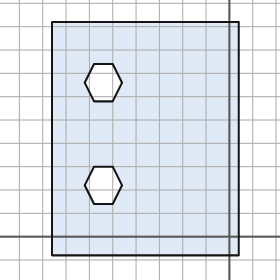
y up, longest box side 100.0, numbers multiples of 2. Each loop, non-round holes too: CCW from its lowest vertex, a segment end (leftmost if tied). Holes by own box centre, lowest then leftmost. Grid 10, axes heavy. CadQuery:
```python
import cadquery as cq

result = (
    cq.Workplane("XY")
    .moveTo(-76.0, -8.0)
    .lineTo(4.0, -8.0)
    .lineTo(4.0, 92.0)
    .lineTo(-76.0, 92.0)
    .close()
    .moveTo(-58.0, 14.0)
    .lineTo(-50.0, 14.0)
    .lineTo(-46.0, 22.0)
    .lineTo(-50.0, 30.0)
    .lineTo(-58.0, 30.0)
    .lineTo(-62.0, 22.0)
    .close()
    .moveTo(-58.0, 58.0)
    .lineTo(-50.0, 58.0)
    .lineTo(-46.0, 66.0)
    .lineTo(-50.0, 74.0)
    .lineTo(-58.0, 74.0)
    .lineTo(-62.0, 66.0)
    .close()
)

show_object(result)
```